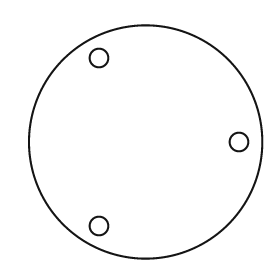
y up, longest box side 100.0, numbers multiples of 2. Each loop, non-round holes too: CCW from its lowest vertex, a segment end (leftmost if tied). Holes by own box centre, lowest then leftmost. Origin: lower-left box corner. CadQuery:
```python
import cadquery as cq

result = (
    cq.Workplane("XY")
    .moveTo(50.0, 50.0)
    .circle(50.0)
    .moveTo(30.0, 14.0)
    .circle(4.0)
    .moveTo(90.0, 50.0)
    .circle(4.0)
    .moveTo(30.0, 86.0)
    .circle(4.0)
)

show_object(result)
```